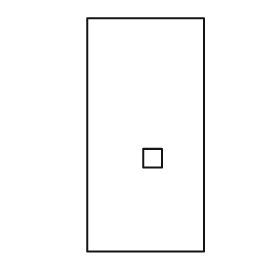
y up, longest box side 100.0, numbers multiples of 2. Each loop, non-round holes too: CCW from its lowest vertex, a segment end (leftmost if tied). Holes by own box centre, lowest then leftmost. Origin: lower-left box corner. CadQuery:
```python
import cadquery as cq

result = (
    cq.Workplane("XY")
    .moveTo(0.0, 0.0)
    .lineTo(50.0, 0.0)
    .lineTo(50.0, 100.0)
    .lineTo(0.0, 100.0)
    .close()
    .moveTo(24.0, 36.0)
    .lineTo(32.0, 36.0)
    .lineTo(32.0, 44.0)
    .lineTo(24.0, 44.0)
    .close()
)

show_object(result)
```